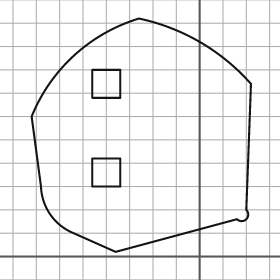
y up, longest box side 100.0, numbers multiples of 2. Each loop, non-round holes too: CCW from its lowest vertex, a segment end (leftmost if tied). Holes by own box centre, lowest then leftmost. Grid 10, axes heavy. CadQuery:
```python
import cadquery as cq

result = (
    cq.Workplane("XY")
    .moveTo(-36.0, 2.0)
    .lineTo(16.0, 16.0)
    .threePointArc((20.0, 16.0), (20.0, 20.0))
    .lineTo(22.0, 74.0)
    .threePointArc((0.0, 92.0), (-26.0, 102.0))
    .threePointArc((-54.0, 86.0), (-72.0, 60.0))
    .lineTo(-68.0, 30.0)
    .threePointArc((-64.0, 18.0), (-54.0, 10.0))
    .close()
    .moveTo(-46.0, 30.0)
    .lineTo(-34.0, 30.0)
    .lineTo(-34.0, 42.0)
    .lineTo(-46.0, 42.0)
    .close()
    .moveTo(-46.0, 68.0)
    .lineTo(-34.0, 68.0)
    .lineTo(-34.0, 80.0)
    .lineTo(-46.0, 80.0)
    .close()
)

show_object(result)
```